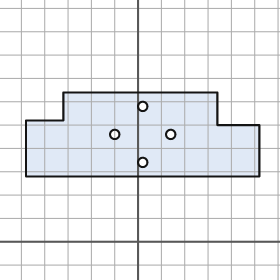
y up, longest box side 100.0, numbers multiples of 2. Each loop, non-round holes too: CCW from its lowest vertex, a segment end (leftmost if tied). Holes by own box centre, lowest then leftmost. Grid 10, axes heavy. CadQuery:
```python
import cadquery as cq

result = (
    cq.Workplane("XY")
    .moveTo(-48.0, 28.0)
    .lineTo(52.0, 28.0)
    .lineTo(52.0, 50.0)
    .lineTo(34.0, 50.0)
    .lineTo(34.0, 64.0)
    .lineTo(-32.0, 64.0)
    .lineTo(-32.0, 52.0)
    .lineTo(-48.0, 52.0)
    .close()
    .moveTo(2.0, 34.0)
    .circle(2.0)
    .moveTo(-10.0, 46.0)
    .circle(2.0)
    .moveTo(14.0, 46.0)
    .circle(2.0)
    .moveTo(2.0, 58.0)
    .circle(2.0)
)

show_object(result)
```